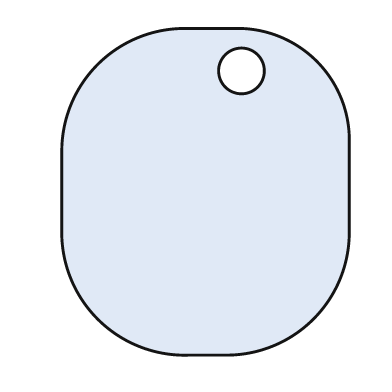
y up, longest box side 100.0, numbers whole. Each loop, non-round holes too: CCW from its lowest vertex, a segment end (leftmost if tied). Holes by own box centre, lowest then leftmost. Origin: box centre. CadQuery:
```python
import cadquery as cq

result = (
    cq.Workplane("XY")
    .moveTo(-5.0, -50.0)
    .lineTo(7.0, -50.0)
    .threePointArc((33.0, -39.0), (44.0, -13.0))
    .lineTo(44.0, 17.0)
    .threePointArc((34.0, 40.0), (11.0, 50.0))
    .lineTo(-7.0, 50.0)
    .threePointArc((-33.0, 39.0), (-44.0, 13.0))
    .lineTo(-44.0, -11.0)
    .threePointArc((-33.0, -39.0), (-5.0, -50.0))
    .close()
    .moveTo(11.0, 37.0)
    .circle(7.0)
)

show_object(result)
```